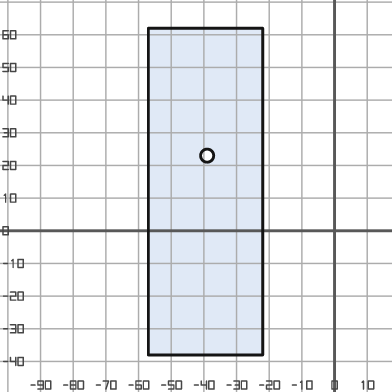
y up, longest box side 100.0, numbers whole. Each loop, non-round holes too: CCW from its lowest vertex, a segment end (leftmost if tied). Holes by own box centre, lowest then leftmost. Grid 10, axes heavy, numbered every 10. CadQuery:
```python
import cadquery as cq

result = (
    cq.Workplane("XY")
    .moveTo(-57.0, -38.0)
    .lineTo(-22.0, -38.0)
    .lineTo(-22.0, 62.0)
    .lineTo(-57.0, 62.0)
    .close()
    .moveTo(-39.0, 23.0)
    .circle(2.0)
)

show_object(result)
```